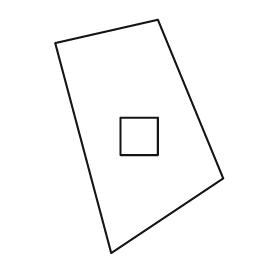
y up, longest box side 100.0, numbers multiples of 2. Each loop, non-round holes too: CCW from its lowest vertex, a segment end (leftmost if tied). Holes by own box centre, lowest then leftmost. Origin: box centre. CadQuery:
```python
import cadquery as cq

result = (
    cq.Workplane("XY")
    .moveTo(-12.0, -50.0)
    .lineTo(36.0, -18.0)
    .lineTo(8.0, 50.0)
    .lineTo(-36.0, 40.0)
    .close()
    .moveTo(-8.0, -8.0)
    .lineTo(8.0, -8.0)
    .lineTo(8.0, 8.0)
    .lineTo(-8.0, 8.0)
    .close()
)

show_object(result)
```